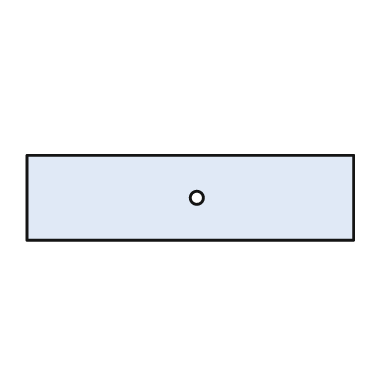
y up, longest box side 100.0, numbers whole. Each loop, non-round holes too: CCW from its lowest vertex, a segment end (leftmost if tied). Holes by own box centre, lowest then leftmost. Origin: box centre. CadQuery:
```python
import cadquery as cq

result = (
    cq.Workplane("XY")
    .moveTo(-50.0, -13.0)
    .lineTo(50.0, -13.0)
    .lineTo(50.0, 13.0)
    .lineTo(-50.0, 13.0)
    .close()
    .moveTo(2.0, 0.0)
    .circle(2.0)
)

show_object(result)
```